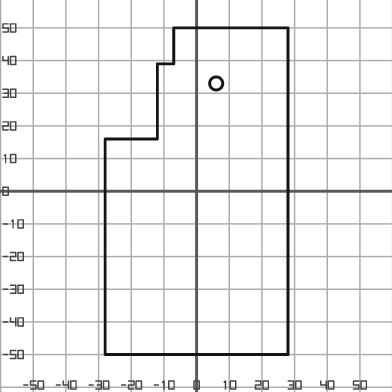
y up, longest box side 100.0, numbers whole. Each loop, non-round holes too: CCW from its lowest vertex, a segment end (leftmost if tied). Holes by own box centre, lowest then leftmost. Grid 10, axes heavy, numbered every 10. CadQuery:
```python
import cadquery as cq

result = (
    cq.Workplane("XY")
    .moveTo(-28.0, -50.0)
    .lineTo(28.0, -50.0)
    .lineTo(28.0, 50.0)
    .lineTo(-7.0, 50.0)
    .lineTo(-7.0, 39.0)
    .lineTo(-12.0, 39.0)
    .lineTo(-12.0, 16.0)
    .lineTo(-28.0, 16.0)
    .close()
    .moveTo(6.0, 33.0)
    .circle(2.0)
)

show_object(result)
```